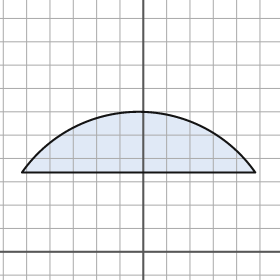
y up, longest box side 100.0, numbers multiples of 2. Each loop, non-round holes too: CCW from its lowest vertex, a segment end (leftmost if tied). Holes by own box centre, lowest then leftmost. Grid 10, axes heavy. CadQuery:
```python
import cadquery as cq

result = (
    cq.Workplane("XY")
    .moveTo(-52.0, 34.0)
    .lineTo(48.0, 34.0)
    .threePointArc((-2.0, 60.0), (-52.0, 34.0))
    .close()
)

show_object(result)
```